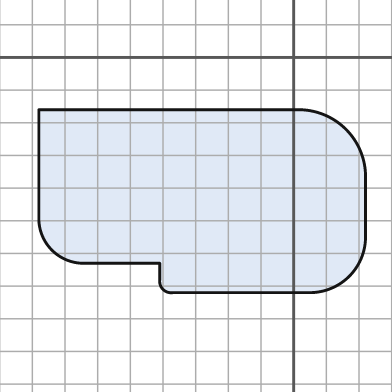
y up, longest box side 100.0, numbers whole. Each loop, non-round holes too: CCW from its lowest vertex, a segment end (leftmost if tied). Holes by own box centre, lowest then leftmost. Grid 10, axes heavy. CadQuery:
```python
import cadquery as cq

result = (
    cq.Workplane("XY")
    .moveTo(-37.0, -72.0)
    .lineTo(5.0, -72.0)
    .threePointArc((17.0, -67.0), (22.0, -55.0))
    .lineTo(22.0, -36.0)
    .threePointArc((16.0, -22.0), (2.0, -16.0))
    .lineTo(-78.0, -16.0)
    .lineTo(-78.0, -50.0)
    .threePointArc((-74.0, -59.0), (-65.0, -63.0))
    .lineTo(-41.0, -63.0)
    .lineTo(-41.0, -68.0)
    .threePointArc((-40.0, -71.0), (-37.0, -72.0))
    .close()
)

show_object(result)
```